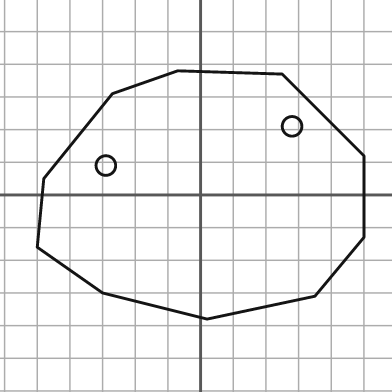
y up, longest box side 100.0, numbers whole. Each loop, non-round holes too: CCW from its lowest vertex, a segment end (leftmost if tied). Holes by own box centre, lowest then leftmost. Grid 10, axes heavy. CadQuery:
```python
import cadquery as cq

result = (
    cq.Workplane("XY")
    .moveTo(2.0, -38.0)
    .lineTo(35.0, -31.0)
    .lineTo(50.0, -13.0)
    .lineTo(50.0, 12.0)
    .lineTo(25.0, 37.0)
    .lineTo(-7.0, 38.0)
    .lineTo(-27.0, 31.0)
    .lineTo(-48.0, 5.0)
    .lineTo(-50.0, -16.0)
    .lineTo(-30.0, -30.0)
    .close()
    .moveTo(-29.0, 9.0)
    .circle(3.0)
    .moveTo(28.0, 21.0)
    .circle(3.0)
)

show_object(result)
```